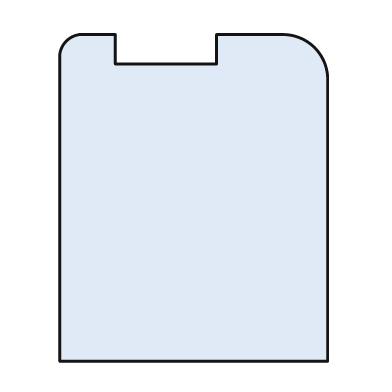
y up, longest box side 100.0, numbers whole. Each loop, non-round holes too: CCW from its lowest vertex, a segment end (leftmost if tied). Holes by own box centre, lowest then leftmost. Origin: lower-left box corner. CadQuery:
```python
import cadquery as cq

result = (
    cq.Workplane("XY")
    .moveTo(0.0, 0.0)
    .lineTo(82.0, 0.0)
    .lineTo(82.0, 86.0)
    .threePointArc((78.0, 96.0), (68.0, 100.0))
    .lineTo(48.0, 100.0)
    .lineTo(48.0, 91.0)
    .lineTo(17.0, 91.0)
    .lineTo(17.0, 100.0)
    .lineTo(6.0, 100.0)
    .threePointArc((2.0, 98.0), (0.0, 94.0))
    .close()
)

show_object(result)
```